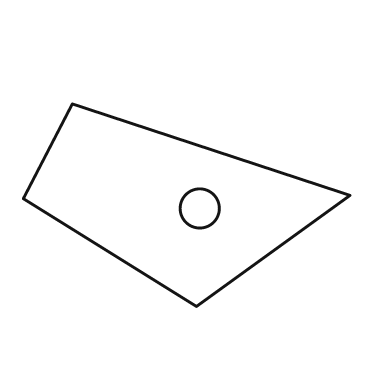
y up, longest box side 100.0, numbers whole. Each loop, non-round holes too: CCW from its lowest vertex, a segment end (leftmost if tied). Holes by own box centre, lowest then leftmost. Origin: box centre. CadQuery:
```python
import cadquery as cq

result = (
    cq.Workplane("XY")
    .moveTo(3.0, -31.0)
    .lineTo(50.0, 3.0)
    .lineTo(-35.0, 31.0)
    .lineTo(-50.0, 2.0)
    .close()
    .moveTo(4.0, -1.0)
    .circle(6.0)
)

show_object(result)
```